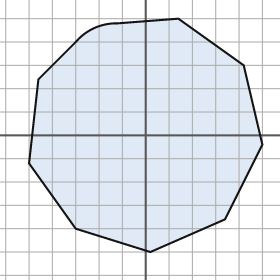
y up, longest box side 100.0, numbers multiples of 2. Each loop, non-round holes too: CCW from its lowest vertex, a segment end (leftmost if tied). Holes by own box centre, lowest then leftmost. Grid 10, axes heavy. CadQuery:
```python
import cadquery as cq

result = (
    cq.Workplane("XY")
    .moveTo(2.0, -50.0)
    .lineTo(34.0, -36.0)
    .lineTo(50.0, -4.0)
    .lineTo(42.0, 30.0)
    .lineTo(14.0, 50.0)
    .lineTo(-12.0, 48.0)
    .threePointArc((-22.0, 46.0), (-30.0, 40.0))
    .lineTo(-46.0, 24.0)
    .lineTo(-50.0, -12.0)
    .lineTo(-30.0, -40.0)
    .close()
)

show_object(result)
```